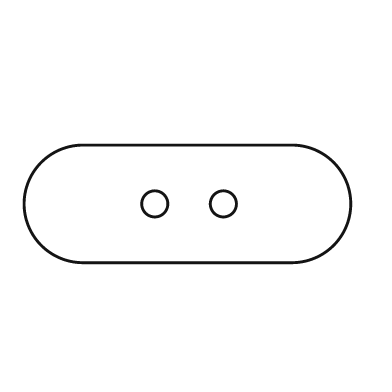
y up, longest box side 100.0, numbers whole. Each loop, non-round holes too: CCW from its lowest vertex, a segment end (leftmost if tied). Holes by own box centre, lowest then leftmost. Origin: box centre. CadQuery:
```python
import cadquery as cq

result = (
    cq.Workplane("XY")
    .moveTo(-32.0, -18.0)
    .lineTo(32.0, -18.0)
    .threePointArc((50.0, 0.0), (32.0, 18.0))
    .lineTo(-32.0, 18.0)
    .threePointArc((-50.0, 0.0), (-32.0, -18.0))
    .close()
    .moveTo(-10.0, 0.0)
    .circle(4.0)
    .moveTo(11.0, 0.0)
    .circle(4.0)
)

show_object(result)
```